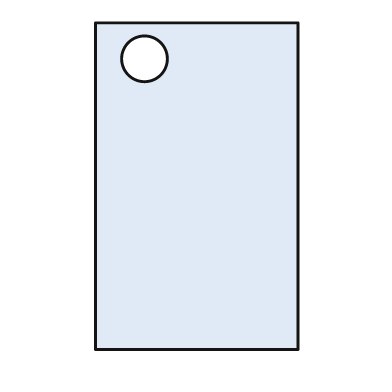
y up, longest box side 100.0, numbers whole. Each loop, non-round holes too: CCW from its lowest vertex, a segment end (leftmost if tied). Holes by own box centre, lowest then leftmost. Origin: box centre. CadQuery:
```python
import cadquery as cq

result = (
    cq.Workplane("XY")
    .moveTo(-31.0, -50.0)
    .lineTo(31.0, -50.0)
    .lineTo(31.0, 50.0)
    .lineTo(-31.0, 50.0)
    .close()
    .moveTo(-16.0, 39.0)
    .circle(7.0)
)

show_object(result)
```